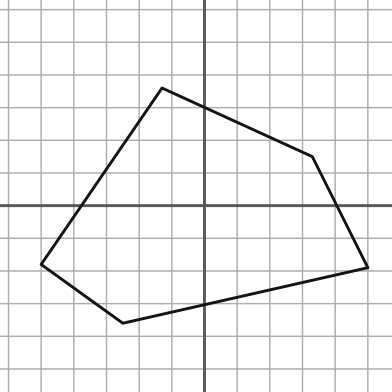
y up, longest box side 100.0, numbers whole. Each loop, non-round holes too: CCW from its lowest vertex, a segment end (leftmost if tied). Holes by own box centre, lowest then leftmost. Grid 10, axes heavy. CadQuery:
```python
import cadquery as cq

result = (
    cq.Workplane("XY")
    .moveTo(-25.0, -36.0)
    .lineTo(50.0, -19.0)
    .lineTo(33.0, 15.0)
    .lineTo(-13.0, 36.0)
    .lineTo(-50.0, -18.0)
    .close()
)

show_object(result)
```